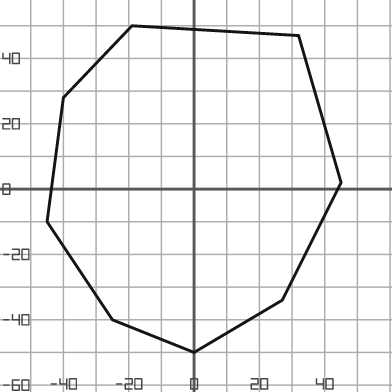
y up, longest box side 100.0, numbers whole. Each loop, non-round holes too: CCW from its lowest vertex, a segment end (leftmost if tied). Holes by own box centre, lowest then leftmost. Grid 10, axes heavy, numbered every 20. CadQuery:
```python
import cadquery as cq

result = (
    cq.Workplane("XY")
    .moveTo(0.0, -50.0)
    .lineTo(27.0, -34.0)
    .lineTo(45.0, 2.0)
    .lineTo(32.0, 47.0)
    .lineTo(-19.0, 50.0)
    .lineTo(-40.0, 28.0)
    .lineTo(-45.0, -10.0)
    .lineTo(-25.0, -40.0)
    .close()
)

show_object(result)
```